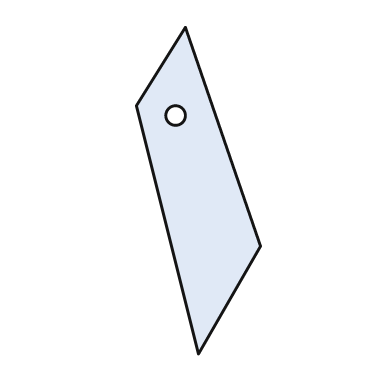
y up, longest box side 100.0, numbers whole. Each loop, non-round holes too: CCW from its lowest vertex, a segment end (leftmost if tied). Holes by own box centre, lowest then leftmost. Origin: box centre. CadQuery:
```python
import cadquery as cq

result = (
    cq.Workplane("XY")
    .moveTo(0.0, -50.0)
    .lineTo(19.0, -17.0)
    .lineTo(-4.0, 50.0)
    .lineTo(-19.0, 26.0)
    .close()
    .moveTo(-7.0, 23.0)
    .circle(3.0)
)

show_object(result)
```